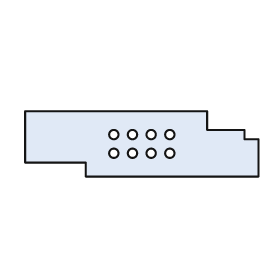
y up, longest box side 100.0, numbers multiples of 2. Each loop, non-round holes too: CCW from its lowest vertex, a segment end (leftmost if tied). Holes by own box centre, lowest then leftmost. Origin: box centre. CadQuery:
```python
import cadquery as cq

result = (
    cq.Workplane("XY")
    .moveTo(-24.0, -14.0)
    .lineTo(50.0, -14.0)
    .lineTo(50.0, 2.0)
    .lineTo(44.0, 2.0)
    .lineTo(44.0, 6.0)
    .lineTo(28.0, 6.0)
    .lineTo(28.0, 14.0)
    .lineTo(-50.0, 14.0)
    .lineTo(-50.0, -8.0)
    .lineTo(-24.0, -8.0)
    .close()
    .moveTo(-12.0, -4.0)
    .circle(2.0)
    .moveTo(-4.0, -4.0)
    .circle(2.0)
    .moveTo(4.0, -4.0)
    .circle(2.0)
    .moveTo(12.0, -4.0)
    .circle(2.0)
    .moveTo(-12.0, 4.0)
    .circle(2.0)
    .moveTo(-4.0, 4.0)
    .circle(2.0)
    .moveTo(4.0, 4.0)
    .circle(2.0)
    .moveTo(12.0, 4.0)
    .circle(2.0)
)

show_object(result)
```